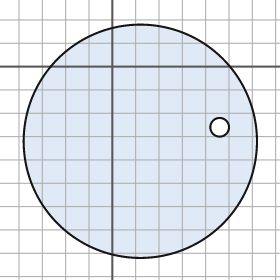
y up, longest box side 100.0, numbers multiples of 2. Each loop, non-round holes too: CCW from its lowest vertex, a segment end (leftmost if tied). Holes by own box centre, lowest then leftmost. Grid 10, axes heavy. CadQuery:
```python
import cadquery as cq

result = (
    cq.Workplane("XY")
    .moveTo(12.0, -32.0)
    .circle(50.0)
    .moveTo(46.0, -26.0)
    .circle(4.0)
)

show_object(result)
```